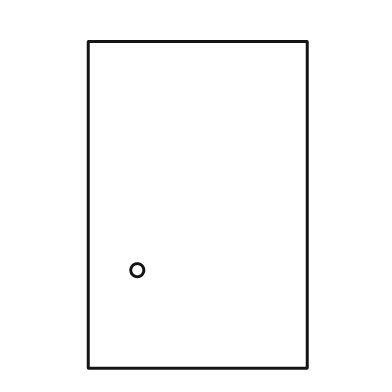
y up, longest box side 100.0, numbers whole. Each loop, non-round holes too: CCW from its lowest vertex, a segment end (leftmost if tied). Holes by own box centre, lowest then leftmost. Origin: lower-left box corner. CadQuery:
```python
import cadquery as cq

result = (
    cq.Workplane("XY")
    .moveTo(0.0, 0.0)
    .lineTo(67.0, 0.0)
    .lineTo(67.0, 100.0)
    .lineTo(0.0, 100.0)
    .close()
    .moveTo(15.0, 30.0)
    .circle(2.0)
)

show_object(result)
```